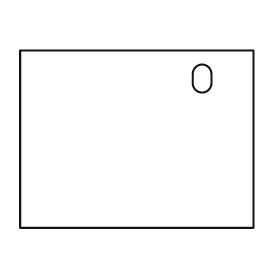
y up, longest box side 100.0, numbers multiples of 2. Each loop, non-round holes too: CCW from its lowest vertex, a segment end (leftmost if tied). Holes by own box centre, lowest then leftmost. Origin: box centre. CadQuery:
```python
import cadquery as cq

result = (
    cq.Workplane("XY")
    .moveTo(-50.0, -38.0)
    .lineTo(50.0, -38.0)
    .lineTo(50.0, 38.0)
    .lineTo(-50.0, 38.0)
    .close()
    .moveTo(24.0, 24.0)
    .threePointArc((28.0, 20.0), (32.0, 24.0))
    .lineTo(32.0, 28.0)
    .threePointArc((28.0, 32.0), (24.0, 28.0))
    .close()
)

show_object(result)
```